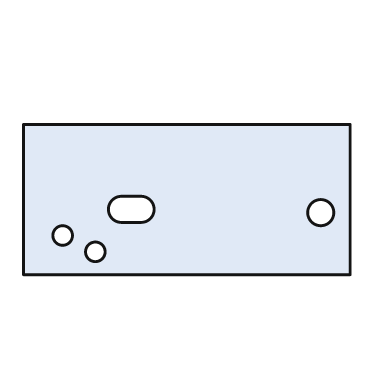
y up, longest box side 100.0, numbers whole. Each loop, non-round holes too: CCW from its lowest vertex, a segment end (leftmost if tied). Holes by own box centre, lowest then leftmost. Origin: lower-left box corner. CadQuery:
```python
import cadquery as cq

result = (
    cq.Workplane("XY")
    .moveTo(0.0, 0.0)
    .lineTo(100.0, 0.0)
    .lineTo(100.0, 46.0)
    .lineTo(0.0, 46.0)
    .close()
    .moveTo(22.0, 7.0)
    .circle(3.0)
    .moveTo(12.0, 12.0)
    .circle(3.0)
    .moveTo(91.0, 19.0)
    .circle(4.0)
    .moveTo(30.0, 16.0)
    .lineTo(36.0, 16.0)
    .threePointArc((40.0, 20.0), (36.0, 24.0))
    .lineTo(30.0, 24.0)
    .threePointArc((26.0, 20.0), (30.0, 16.0))
    .close()
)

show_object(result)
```